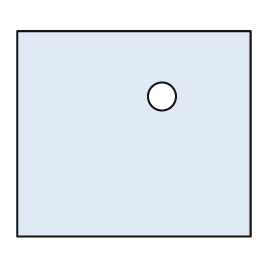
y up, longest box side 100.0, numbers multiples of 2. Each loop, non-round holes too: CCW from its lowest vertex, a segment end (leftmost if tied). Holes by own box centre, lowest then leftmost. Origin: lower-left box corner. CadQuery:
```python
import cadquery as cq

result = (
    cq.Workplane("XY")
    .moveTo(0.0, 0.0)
    .lineTo(100.0, 0.0)
    .lineTo(100.0, 88.0)
    .lineTo(0.0, 88.0)
    .close()
    .moveTo(62.0, 60.0)
    .circle(6.0)
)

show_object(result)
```